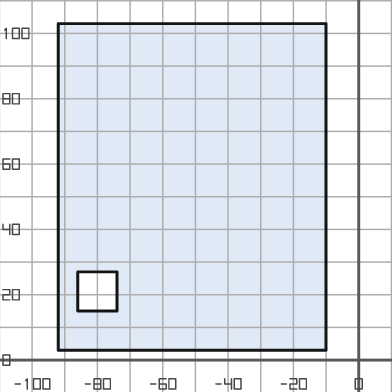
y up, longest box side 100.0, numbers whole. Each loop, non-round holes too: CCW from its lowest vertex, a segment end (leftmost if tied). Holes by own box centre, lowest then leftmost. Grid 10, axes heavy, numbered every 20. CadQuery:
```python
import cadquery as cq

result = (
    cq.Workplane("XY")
    .moveTo(-92.0, 3.0)
    .lineTo(-10.0, 3.0)
    .lineTo(-10.0, 103.0)
    .lineTo(-92.0, 103.0)
    .close()
    .moveTo(-86.0, 15.0)
    .lineTo(-74.0, 15.0)
    .lineTo(-74.0, 27.0)
    .lineTo(-86.0, 27.0)
    .close()
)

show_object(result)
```